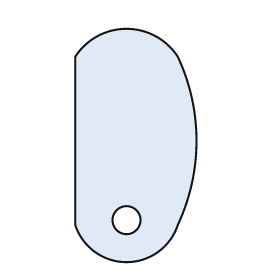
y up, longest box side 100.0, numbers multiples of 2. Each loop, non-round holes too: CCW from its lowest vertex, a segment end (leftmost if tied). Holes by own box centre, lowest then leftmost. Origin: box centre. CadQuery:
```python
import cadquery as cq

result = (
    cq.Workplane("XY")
    .moveTo(-26.0, -34.0)
    .threePointArc((-4.0, -50.0), (18.0, -34.0))
    .threePointArc((26.0, 2.0), (18.0, 38.0))
    .threePointArc((-4.0, 50.0), (-26.0, 38.0))
    .close()
    .moveTo(-4.0, -32.0)
    .circle(6.0)
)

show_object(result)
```